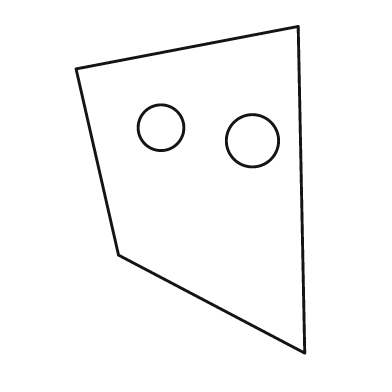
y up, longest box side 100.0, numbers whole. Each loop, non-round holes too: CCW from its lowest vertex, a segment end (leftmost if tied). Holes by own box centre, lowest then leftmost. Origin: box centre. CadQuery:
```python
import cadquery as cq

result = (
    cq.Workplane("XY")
    .moveTo(35.0, -50.0)
    .lineTo(33.0, 50.0)
    .lineTo(-35.0, 37.0)
    .lineTo(-22.0, -20.0)
    .close()
    .moveTo(19.0, 15.0)
    .circle(8.0)
    .moveTo(-9.0, 19.0)
    .circle(7.0)
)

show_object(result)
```